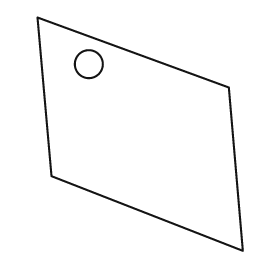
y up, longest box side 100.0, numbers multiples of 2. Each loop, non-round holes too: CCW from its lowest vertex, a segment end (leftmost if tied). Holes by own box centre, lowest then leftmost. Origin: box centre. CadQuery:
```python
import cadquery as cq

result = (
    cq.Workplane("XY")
    .moveTo(44.0, -50.0)
    .lineTo(38.0, 20.0)
    .lineTo(-44.0, 50.0)
    .lineTo(-38.0, -18.0)
    .close()
    .moveTo(-22.0, 30.0)
    .circle(6.0)
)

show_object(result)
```